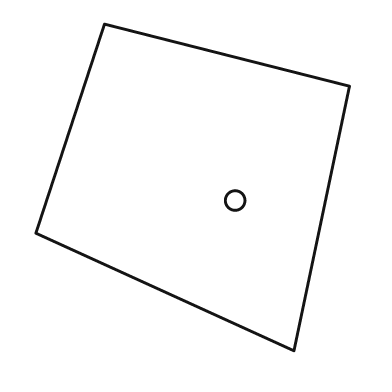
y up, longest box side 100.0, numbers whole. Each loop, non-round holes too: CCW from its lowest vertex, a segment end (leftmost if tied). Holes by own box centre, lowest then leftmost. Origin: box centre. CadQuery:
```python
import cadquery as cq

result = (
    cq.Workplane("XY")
    .moveTo(31.0, -50.0)
    .lineTo(48.0, 31.0)
    .lineTo(-27.0, 50.0)
    .lineTo(-48.0, -14.0)
    .close()
    .moveTo(13.0, -4.0)
    .circle(3.0)
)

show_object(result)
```